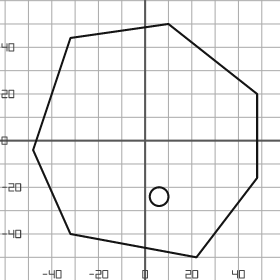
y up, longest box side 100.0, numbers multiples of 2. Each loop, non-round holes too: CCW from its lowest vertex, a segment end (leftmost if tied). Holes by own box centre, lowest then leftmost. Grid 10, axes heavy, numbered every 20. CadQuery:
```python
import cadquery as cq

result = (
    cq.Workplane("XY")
    .moveTo(22.0, -50.0)
    .lineTo(48.0, -16.0)
    .lineTo(48.0, 20.0)
    .lineTo(10.0, 50.0)
    .lineTo(-32.0, 44.0)
    .lineTo(-48.0, -4.0)
    .lineTo(-32.0, -40.0)
    .close()
    .moveTo(6.0, -24.0)
    .circle(4.0)
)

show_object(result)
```